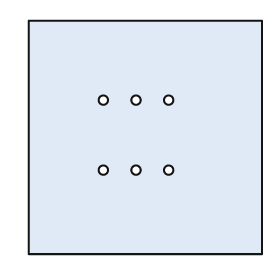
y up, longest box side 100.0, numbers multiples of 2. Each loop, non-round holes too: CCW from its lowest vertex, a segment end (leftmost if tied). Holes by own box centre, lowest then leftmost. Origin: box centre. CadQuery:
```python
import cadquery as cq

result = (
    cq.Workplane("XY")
    .moveTo(-50.0, -50.0)
    .lineTo(50.0, -50.0)
    .lineTo(50.0, 50.0)
    .lineTo(-50.0, 50.0)
    .close()
    .moveTo(-18.0, -14.0)
    .circle(2.0)
    .moveTo(-4.0, -14.0)
    .circle(2.0)
    .moveTo(10.0, -14.0)
    .circle(2.0)
    .moveTo(-18.0, 16.0)
    .circle(2.0)
    .moveTo(-4.0, 16.0)
    .circle(2.0)
    .moveTo(10.0, 16.0)
    .circle(2.0)
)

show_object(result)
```